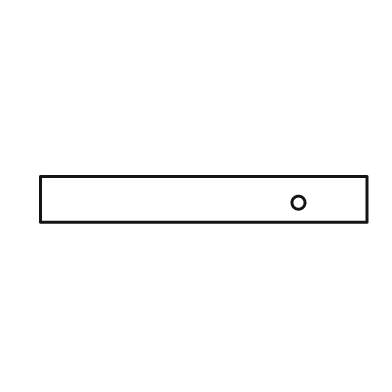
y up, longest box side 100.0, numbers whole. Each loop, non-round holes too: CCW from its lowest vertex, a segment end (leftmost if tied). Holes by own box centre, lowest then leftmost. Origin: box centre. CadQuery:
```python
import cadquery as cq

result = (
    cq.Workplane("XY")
    .moveTo(-50.0, -7.0)
    .lineTo(50.0, -7.0)
    .lineTo(50.0, 7.0)
    .lineTo(-50.0, 7.0)
    .close()
    .moveTo(29.0, -1.0)
    .circle(2.0)
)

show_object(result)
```